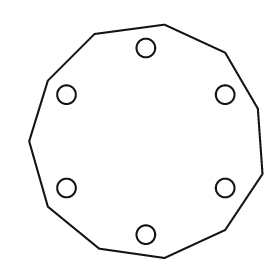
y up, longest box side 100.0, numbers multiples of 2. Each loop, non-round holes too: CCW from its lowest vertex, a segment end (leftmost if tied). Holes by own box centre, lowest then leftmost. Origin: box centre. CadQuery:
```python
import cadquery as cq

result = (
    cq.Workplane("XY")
    .moveTo(8.0, -50.0)
    .lineTo(34.0, -38.0)
    .lineTo(50.0, -14.0)
    .lineTo(48.0, 14.0)
    .lineTo(34.0, 38.0)
    .lineTo(8.0, 50.0)
    .lineTo(-22.0, 46.0)
    .lineTo(-42.0, 26.0)
    .lineTo(-50.0, 0.0)
    .lineTo(-42.0, -28.0)
    .lineTo(-20.0, -46.0)
    .close()
    .moveTo(0.0, -40.0)
    .circle(4.0)
    .moveTo(-34.0, -20.0)
    .circle(4.0)
    .moveTo(34.0, -20.0)
    .circle(4.0)
    .moveTo(-34.0, 20.0)
    .circle(4.0)
    .moveTo(34.0, 20.0)
    .circle(4.0)
    .moveTo(0.0, 40.0)
    .circle(4.0)
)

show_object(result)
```